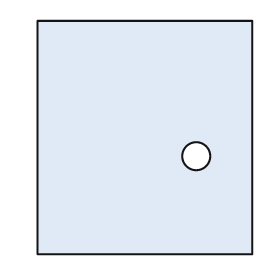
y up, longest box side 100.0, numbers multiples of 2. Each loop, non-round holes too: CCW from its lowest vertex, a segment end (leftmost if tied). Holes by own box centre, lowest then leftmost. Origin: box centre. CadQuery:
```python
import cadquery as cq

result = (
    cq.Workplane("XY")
    .moveTo(-46.0, -50.0)
    .lineTo(46.0, -50.0)
    .lineTo(46.0, 50.0)
    .lineTo(-46.0, 50.0)
    .close()
    .moveTo(22.0, -8.0)
    .circle(6.0)
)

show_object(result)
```